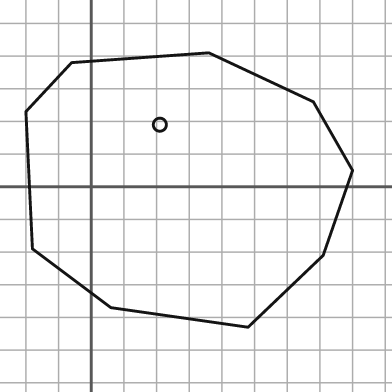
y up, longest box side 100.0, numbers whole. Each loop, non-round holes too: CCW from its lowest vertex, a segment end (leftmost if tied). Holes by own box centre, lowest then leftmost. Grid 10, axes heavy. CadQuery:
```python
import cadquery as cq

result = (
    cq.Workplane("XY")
    .moveTo(48.0, -43.0)
    .lineTo(71.0, -21.0)
    .lineTo(80.0, 5.0)
    .lineTo(68.0, 26.0)
    .lineTo(36.0, 41.0)
    .lineTo(-6.0, 38.0)
    .lineTo(-20.0, 23.0)
    .lineTo(-18.0, -19.0)
    .lineTo(6.0, -37.0)
    .close()
    .moveTo(21.0, 19.0)
    .circle(2.0)
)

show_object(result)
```